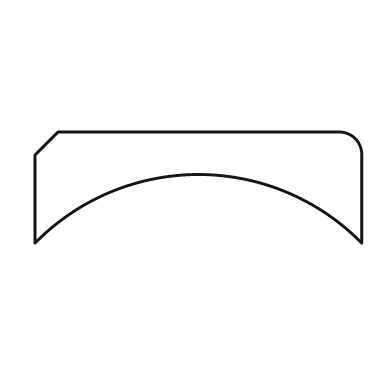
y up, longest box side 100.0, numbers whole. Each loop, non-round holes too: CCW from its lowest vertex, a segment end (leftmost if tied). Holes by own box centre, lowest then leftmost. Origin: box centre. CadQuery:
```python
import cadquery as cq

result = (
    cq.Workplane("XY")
    .moveTo(-50.0, -17.0)
    .threePointArc((0.0, 4.0), (50.0, -17.0))
    .lineTo(50.0, 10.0)
    .threePointArc((48.0, 15.0), (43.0, 17.0))
    .lineTo(-43.0, 17.0)
    .lineTo(-50.0, 10.0)
    .close()
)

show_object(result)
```